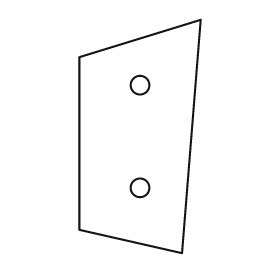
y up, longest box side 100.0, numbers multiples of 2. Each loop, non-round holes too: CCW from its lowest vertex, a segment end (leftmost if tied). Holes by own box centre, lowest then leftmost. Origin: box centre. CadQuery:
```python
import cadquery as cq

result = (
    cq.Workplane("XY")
    .moveTo(18.0, -50.0)
    .lineTo(26.0, 50.0)
    .lineTo(-26.0, 34.0)
    .lineTo(-26.0, -40.0)
    .close()
    .moveTo(0.0, -22.0)
    .circle(4.0)
    .moveTo(0.0, 22.0)
    .circle(4.0)
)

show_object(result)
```